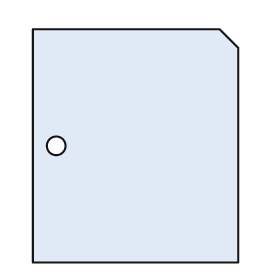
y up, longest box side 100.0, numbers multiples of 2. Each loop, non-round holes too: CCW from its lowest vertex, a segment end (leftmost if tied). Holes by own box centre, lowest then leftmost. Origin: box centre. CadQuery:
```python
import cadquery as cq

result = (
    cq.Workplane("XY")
    .moveTo(-44.0, -50.0)
    .lineTo(44.0, -50.0)
    .lineTo(44.0, 42.0)
    .lineTo(36.0, 50.0)
    .lineTo(-44.0, 50.0)
    .close()
    .moveTo(-34.0, 0.0)
    .circle(4.0)
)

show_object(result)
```